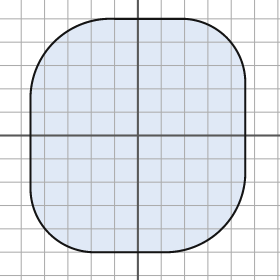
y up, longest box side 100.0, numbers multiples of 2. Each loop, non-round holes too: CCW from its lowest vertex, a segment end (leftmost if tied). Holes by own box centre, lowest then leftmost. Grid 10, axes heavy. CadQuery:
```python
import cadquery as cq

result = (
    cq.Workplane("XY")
    .moveTo(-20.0, -50.0)
    .lineTo(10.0, -50.0)
    .threePointArc((36.0, -40.0), (46.0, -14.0))
    .lineTo(46.0, 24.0)
    .threePointArc((38.0, 42.0), (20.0, 50.0))
    .lineTo(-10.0, 50.0)
    .threePointArc((-36.0, 40.0), (-46.0, 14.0))
    .lineTo(-46.0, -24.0)
    .threePointArc((-38.0, -42.0), (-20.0, -50.0))
    .close()
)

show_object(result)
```